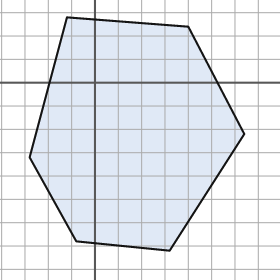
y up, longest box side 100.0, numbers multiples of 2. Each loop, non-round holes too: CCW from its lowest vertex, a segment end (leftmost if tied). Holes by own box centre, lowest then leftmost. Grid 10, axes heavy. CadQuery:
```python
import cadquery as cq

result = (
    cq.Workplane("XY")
    .moveTo(32.0, -72.0)
    .lineTo(64.0, -22.0)
    .lineTo(40.0, 24.0)
    .lineTo(-12.0, 28.0)
    .lineTo(-28.0, -32.0)
    .lineTo(-8.0, -68.0)
    .close()
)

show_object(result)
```